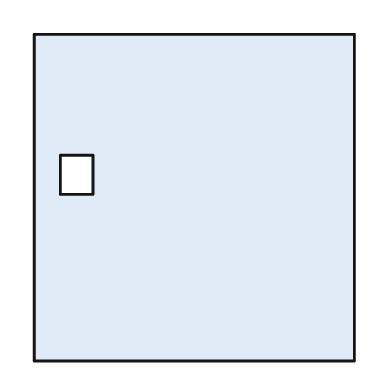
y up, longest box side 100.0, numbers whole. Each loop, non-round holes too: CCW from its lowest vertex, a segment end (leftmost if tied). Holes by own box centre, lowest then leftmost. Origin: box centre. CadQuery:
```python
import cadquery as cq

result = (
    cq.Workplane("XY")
    .moveTo(-49.0, -50.0)
    .lineTo(49.0, -50.0)
    .lineTo(49.0, 50.0)
    .lineTo(-49.0, 50.0)
    .close()
    .moveTo(-41.0, 1.0)
    .lineTo(-31.0, 1.0)
    .lineTo(-31.0, 13.0)
    .lineTo(-41.0, 13.0)
    .close()
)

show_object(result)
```